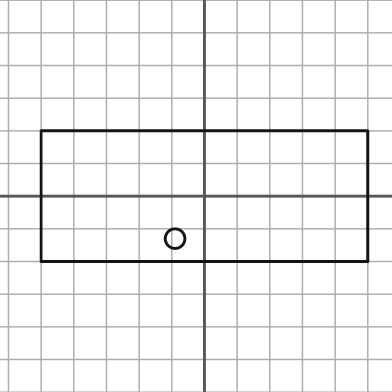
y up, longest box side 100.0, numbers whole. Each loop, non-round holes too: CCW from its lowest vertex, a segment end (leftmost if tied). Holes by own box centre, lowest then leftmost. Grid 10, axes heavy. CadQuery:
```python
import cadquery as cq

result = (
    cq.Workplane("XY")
    .moveTo(-50.0, -20.0)
    .lineTo(50.0, -20.0)
    .lineTo(50.0, 20.0)
    .lineTo(-50.0, 20.0)
    .close()
    .moveTo(-9.0, -13.0)
    .circle(3.0)
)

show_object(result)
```